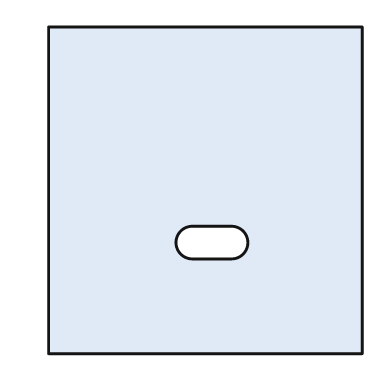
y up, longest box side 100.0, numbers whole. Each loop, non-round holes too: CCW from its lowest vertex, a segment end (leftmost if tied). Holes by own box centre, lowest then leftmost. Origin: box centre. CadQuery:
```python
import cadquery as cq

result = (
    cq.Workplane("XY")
    .moveTo(-48.0, -50.0)
    .lineTo(48.0, -50.0)
    .lineTo(48.0, 50.0)
    .lineTo(-48.0, 50.0)
    .close()
    .moveTo(-4.0, -21.0)
    .lineTo(8.0, -21.0)
    .threePointArc((13.0, -16.0), (8.0, -11.0))
    .lineTo(-4.0, -11.0)
    .threePointArc((-9.0, -16.0), (-4.0, -21.0))
    .close()
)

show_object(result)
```